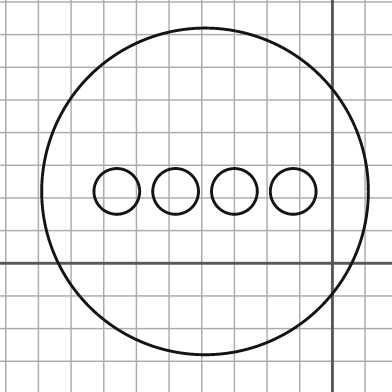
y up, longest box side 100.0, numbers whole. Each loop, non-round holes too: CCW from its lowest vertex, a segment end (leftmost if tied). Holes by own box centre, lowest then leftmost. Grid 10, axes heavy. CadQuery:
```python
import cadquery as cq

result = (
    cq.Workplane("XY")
    .moveTo(-39.0, 22.0)
    .circle(50.0)
    .moveTo(-66.0, 22.0)
    .circle(7.0)
    .moveTo(-48.0, 22.0)
    .circle(7.0)
    .moveTo(-30.0, 22.0)
    .circle(7.0)
    .moveTo(-12.0, 22.0)
    .circle(7.0)
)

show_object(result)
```